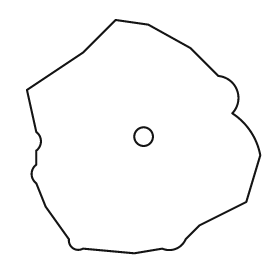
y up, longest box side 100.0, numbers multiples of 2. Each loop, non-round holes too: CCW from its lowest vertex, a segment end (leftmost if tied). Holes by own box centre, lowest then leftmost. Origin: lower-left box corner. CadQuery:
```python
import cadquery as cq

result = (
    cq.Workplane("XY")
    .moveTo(46.0, 0.0)
    .lineTo(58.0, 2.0)
    .threePointArc((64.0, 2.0), (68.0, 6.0))
    .lineTo(74.0, 12.0)
    .lineTo(94.0, 22.0)
    .lineTo(100.0, 42.0)
    .threePointArc((96.0, 52.0), (88.0, 60.0))
    .threePointArc((90.0, 70.0), (82.0, 76.0))
    .lineTo(70.0, 88.0)
    .lineTo(52.0, 98.0)
    .lineTo(38.0, 100.0)
    .lineTo(24.0, 86.0)
    .lineTo(0.0, 70.0)
    .lineTo(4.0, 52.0)
    .threePointArc((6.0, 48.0), (4.0, 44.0))
    .lineTo(4.0, 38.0)
    .threePointArc((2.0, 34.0), (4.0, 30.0))
    .lineTo(8.0, 20.0)
    .lineTo(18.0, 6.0)
    .threePointArc((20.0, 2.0), (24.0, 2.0))
    .close()
    .moveTo(50.0, 50.0)
    .circle(4.0)
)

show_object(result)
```